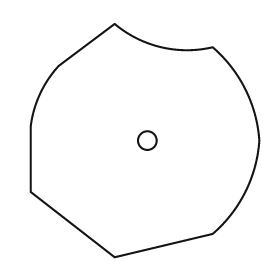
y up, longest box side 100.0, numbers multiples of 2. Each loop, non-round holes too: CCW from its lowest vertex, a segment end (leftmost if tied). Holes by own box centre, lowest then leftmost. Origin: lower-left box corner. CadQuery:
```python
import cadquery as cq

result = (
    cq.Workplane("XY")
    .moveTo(36.0, 0.0)
    .lineTo(78.0, 10.0)
    .threePointArc((92.0, 28.0), (98.0, 50.0))
    .threePointArc((92.0, 72.0), (78.0, 90.0))
    .threePointArc((56.0, 90.0), (36.0, 100.0))
    .lineTo(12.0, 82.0)
    .threePointArc((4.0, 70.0), (0.0, 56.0))
    .lineTo(0.0, 28.0)
    .close()
    .moveTo(50.0, 50.0)
    .circle(4.0)
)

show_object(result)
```